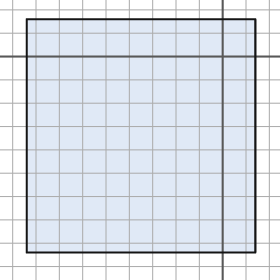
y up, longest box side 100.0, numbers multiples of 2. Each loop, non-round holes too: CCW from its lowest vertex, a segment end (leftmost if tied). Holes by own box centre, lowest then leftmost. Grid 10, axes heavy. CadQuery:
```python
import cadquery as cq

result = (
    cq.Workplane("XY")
    .moveTo(-84.0, -84.0)
    .lineTo(14.0, -84.0)
    .lineTo(14.0, 16.0)
    .lineTo(-84.0, 16.0)
    .close()
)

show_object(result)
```